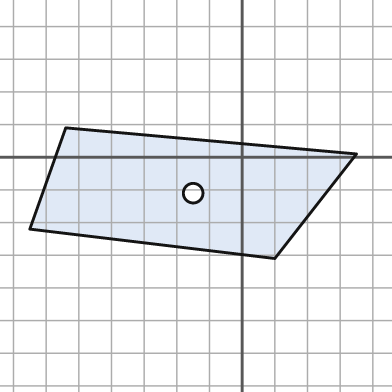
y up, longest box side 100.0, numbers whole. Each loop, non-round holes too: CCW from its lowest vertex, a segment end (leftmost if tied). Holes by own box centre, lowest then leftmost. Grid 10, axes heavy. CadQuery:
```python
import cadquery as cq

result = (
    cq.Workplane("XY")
    .moveTo(10.0, -31.0)
    .lineTo(35.0, 1.0)
    .lineTo(-54.0, 9.0)
    .lineTo(-65.0, -22.0)
    .close()
    .moveTo(-15.0, -11.0)
    .circle(3.0)
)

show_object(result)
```